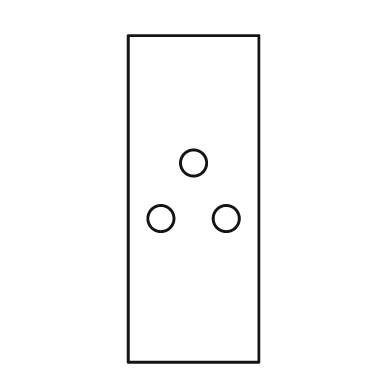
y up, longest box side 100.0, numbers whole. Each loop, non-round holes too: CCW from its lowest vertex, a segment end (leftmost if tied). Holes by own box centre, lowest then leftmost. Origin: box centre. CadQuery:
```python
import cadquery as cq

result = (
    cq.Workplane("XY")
    .moveTo(-20.0, -50.0)
    .lineTo(20.0, -50.0)
    .lineTo(20.0, 50.0)
    .lineTo(-20.0, 50.0)
    .close()
    .moveTo(-10.0, -6.0)
    .circle(4.0)
    .moveTo(10.0, -6.0)
    .circle(4.0)
    .moveTo(0.0, 11.0)
    .circle(4.0)
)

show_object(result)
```